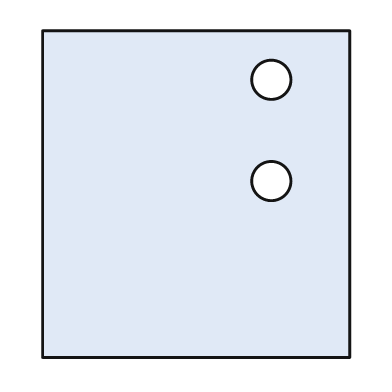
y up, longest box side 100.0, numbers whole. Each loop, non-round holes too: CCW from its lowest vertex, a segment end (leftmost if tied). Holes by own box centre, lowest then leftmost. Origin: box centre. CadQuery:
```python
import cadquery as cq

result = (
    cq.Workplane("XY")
    .moveTo(-47.0, -50.0)
    .lineTo(47.0, -50.0)
    .lineTo(47.0, 50.0)
    .lineTo(-47.0, 50.0)
    .close()
    .moveTo(23.0, 4.0)
    .circle(6.0)
    .moveTo(23.0, 35.0)
    .circle(6.0)
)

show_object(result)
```